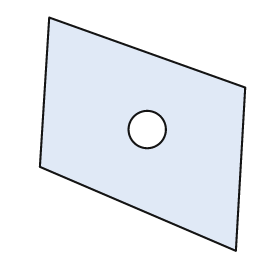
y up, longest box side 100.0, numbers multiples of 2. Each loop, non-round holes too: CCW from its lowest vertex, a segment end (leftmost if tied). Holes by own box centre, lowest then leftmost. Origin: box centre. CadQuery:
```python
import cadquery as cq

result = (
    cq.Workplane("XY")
    .moveTo(40.0, -50.0)
    .lineTo(44.0, 20.0)
    .lineTo(-40.0, 50.0)
    .lineTo(-44.0, -14.0)
    .close()
    .moveTo(2.0, 2.0)
    .circle(8.0)
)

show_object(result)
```